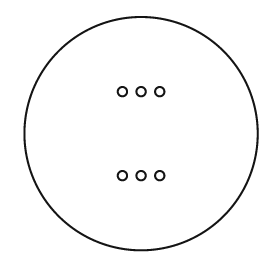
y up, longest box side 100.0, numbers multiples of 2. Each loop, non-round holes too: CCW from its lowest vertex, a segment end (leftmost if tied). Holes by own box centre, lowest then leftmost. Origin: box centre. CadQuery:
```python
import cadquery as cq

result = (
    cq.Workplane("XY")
    .moveTo(0.0, 0.0)
    .circle(50.0)
    .moveTo(-8.0, -18.0)
    .circle(2.0)
    .moveTo(0.0, -18.0)
    .circle(2.0)
    .moveTo(8.0, -18.0)
    .circle(2.0)
    .moveTo(-8.0, 18.0)
    .circle(2.0)
    .moveTo(0.0, 18.0)
    .circle(2.0)
    .moveTo(8.0, 18.0)
    .circle(2.0)
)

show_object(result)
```